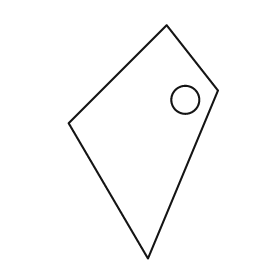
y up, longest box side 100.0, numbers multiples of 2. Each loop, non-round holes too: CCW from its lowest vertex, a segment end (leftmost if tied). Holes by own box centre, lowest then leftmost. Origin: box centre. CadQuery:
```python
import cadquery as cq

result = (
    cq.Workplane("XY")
    .moveTo(2.0, -50.0)
    .lineTo(32.0, 22.0)
    .lineTo(10.0, 50.0)
    .lineTo(-32.0, 8.0)
    .close()
    .moveTo(18.0, 18.0)
    .circle(6.0)
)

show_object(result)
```